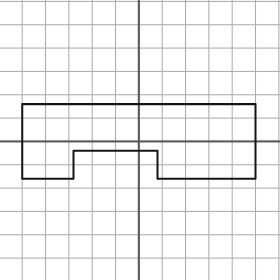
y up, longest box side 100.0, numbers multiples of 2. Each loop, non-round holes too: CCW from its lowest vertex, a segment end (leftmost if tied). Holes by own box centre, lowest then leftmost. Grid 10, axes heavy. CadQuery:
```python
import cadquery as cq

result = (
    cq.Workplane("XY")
    .moveTo(-50.0, -16.0)
    .lineTo(-28.0, -16.0)
    .lineTo(-28.0, -4.0)
    .lineTo(8.0, -4.0)
    .lineTo(8.0, -16.0)
    .lineTo(50.0, -16.0)
    .lineTo(50.0, 16.0)
    .lineTo(-50.0, 16.0)
    .close()
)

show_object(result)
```